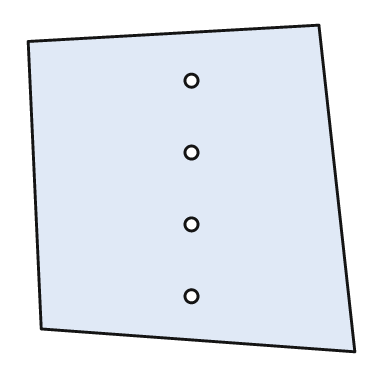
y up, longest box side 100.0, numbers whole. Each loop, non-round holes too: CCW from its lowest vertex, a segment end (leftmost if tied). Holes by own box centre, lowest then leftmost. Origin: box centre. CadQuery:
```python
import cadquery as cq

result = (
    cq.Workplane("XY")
    .moveTo(50.0, -50.0)
    .lineTo(39.0, 50.0)
    .lineTo(-50.0, 45.0)
    .lineTo(-46.0, -43.0)
    .close()
    .moveTo(0.0, -33.0)
    .circle(2.0)
    .moveTo(0.0, -11.0)
    .circle(2.0)
    .moveTo(0.0, 11.0)
    .circle(2.0)
    .moveTo(0.0, 33.0)
    .circle(2.0)
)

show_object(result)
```